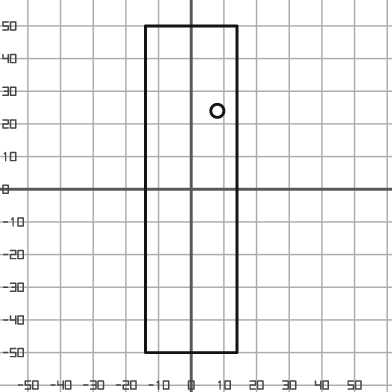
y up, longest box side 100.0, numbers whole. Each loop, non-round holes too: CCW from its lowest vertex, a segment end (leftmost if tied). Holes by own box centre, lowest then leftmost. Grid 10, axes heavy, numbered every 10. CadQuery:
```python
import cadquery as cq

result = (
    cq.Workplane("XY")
    .moveTo(-14.0, -50.0)
    .lineTo(14.0, -50.0)
    .lineTo(14.0, 50.0)
    .lineTo(-14.0, 50.0)
    .close()
    .moveTo(8.0, 24.0)
    .circle(2.0)
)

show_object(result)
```